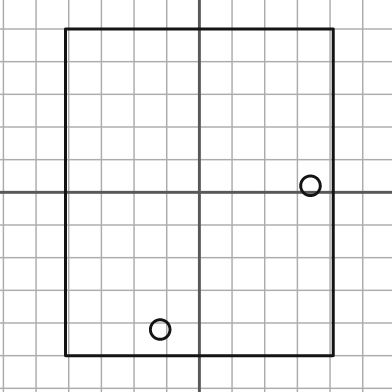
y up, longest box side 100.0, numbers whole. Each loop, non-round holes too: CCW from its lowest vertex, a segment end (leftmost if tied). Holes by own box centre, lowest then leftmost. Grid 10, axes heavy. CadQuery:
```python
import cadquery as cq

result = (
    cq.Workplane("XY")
    .moveTo(-41.0, -50.0)
    .lineTo(41.0, -50.0)
    .lineTo(41.0, 50.0)
    .lineTo(-41.0, 50.0)
    .close()
    .moveTo(-12.0, -42.0)
    .circle(3.0)
    .moveTo(34.0, 2.0)
    .circle(3.0)
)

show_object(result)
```